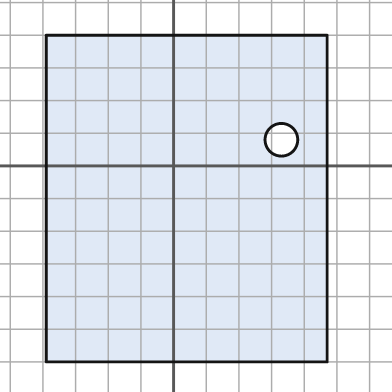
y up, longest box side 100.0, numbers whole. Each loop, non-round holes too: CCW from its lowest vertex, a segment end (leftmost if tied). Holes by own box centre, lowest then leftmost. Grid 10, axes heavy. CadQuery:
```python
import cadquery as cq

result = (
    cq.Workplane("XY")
    .moveTo(-39.0, -60.0)
    .lineTo(47.0, -60.0)
    .lineTo(47.0, 40.0)
    .lineTo(-39.0, 40.0)
    .close()
    .moveTo(33.0, 8.0)
    .circle(5.0)
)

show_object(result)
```